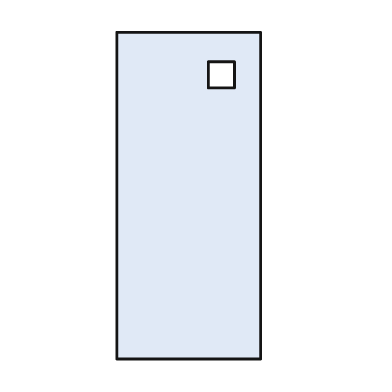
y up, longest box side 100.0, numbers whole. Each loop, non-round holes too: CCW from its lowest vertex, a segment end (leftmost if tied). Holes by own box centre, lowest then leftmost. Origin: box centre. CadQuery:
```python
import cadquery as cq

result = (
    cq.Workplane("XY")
    .moveTo(-22.0, -50.0)
    .lineTo(22.0, -50.0)
    .lineTo(22.0, 50.0)
    .lineTo(-22.0, 50.0)
    .close()
    .moveTo(6.0, 33.0)
    .lineTo(14.0, 33.0)
    .lineTo(14.0, 41.0)
    .lineTo(6.0, 41.0)
    .close()
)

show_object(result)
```